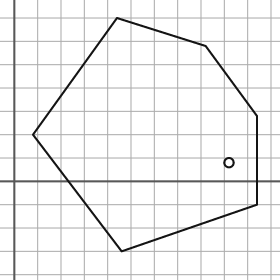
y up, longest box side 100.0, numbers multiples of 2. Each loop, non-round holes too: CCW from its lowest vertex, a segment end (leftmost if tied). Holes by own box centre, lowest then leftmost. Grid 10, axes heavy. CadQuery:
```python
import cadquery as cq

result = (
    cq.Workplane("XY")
    .moveTo(46.0, -30.0)
    .lineTo(104.0, -10.0)
    .lineTo(104.0, 28.0)
    .lineTo(82.0, 58.0)
    .lineTo(44.0, 70.0)
    .lineTo(8.0, 20.0)
    .close()
    .moveTo(92.0, 8.0)
    .circle(2.0)
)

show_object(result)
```